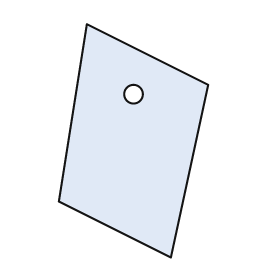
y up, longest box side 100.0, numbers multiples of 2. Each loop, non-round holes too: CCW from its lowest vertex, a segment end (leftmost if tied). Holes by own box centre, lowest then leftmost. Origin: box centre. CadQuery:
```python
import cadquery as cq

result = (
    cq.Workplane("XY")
    .moveTo(16.0, -50.0)
    .lineTo(32.0, 24.0)
    .lineTo(-20.0, 50.0)
    .lineTo(-32.0, -26.0)
    .close()
    .moveTo(0.0, 20.0)
    .circle(4.0)
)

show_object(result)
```